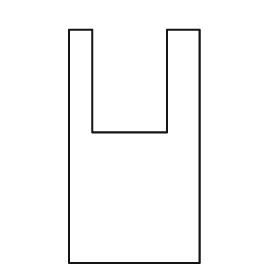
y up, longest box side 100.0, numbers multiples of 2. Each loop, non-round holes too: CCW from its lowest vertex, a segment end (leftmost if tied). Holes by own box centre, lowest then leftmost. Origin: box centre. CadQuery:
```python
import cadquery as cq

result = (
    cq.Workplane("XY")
    .moveTo(-28.0, -50.0)
    .lineTo(28.0, -50.0)
    .lineTo(28.0, 50.0)
    .lineTo(14.0, 50.0)
    .lineTo(14.0, 6.0)
    .lineTo(-18.0, 6.0)
    .lineTo(-18.0, 50.0)
    .lineTo(-28.0, 50.0)
    .close()
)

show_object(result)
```